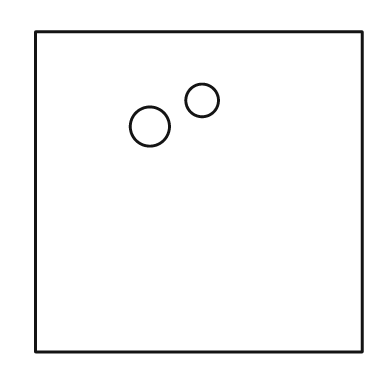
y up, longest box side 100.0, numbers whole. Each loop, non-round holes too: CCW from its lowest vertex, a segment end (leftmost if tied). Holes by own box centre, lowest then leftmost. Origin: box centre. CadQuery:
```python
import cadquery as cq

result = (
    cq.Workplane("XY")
    .moveTo(-50.0, -49.0)
    .lineTo(50.0, -49.0)
    .lineTo(50.0, 49.0)
    .lineTo(-50.0, 49.0)
    .close()
    .moveTo(-15.0, 20.0)
    .circle(6.0)
    .moveTo(1.0, 28.0)
    .circle(5.0)
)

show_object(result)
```